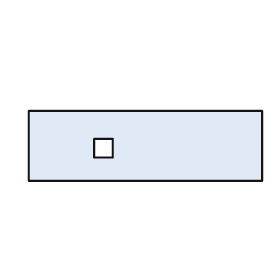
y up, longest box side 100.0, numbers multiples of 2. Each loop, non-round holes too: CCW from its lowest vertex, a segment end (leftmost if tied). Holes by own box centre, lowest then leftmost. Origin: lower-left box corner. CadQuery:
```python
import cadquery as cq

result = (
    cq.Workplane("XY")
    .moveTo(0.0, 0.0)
    .lineTo(100.0, 0.0)
    .lineTo(100.0, 30.0)
    .lineTo(0.0, 30.0)
    .close()
    .moveTo(28.0, 10.0)
    .lineTo(36.0, 10.0)
    .lineTo(36.0, 18.0)
    .lineTo(28.0, 18.0)
    .close()
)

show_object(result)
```